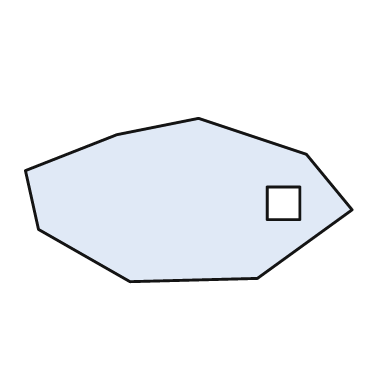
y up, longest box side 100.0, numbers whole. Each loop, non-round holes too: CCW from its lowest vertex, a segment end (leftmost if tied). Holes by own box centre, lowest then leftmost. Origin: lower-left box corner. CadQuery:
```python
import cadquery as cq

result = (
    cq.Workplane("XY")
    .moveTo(32.0, 0.0)
    .lineTo(71.0, 1.0)
    .lineTo(100.0, 22.0)
    .lineTo(86.0, 39.0)
    .lineTo(53.0, 50.0)
    .lineTo(28.0, 45.0)
    .lineTo(0.0, 34.0)
    .lineTo(4.0, 16.0)
    .close()
    .moveTo(74.0, 19.0)
    .lineTo(84.0, 19.0)
    .lineTo(84.0, 29.0)
    .lineTo(74.0, 29.0)
    .close()
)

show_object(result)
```